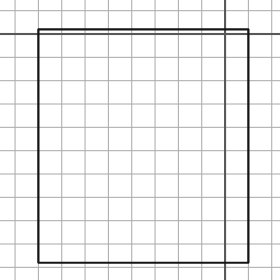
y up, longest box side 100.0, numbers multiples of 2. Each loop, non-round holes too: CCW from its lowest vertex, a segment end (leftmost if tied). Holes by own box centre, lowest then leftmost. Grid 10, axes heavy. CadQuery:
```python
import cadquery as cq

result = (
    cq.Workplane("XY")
    .moveTo(-80.0, -98.0)
    .lineTo(10.0, -98.0)
    .lineTo(10.0, 2.0)
    .lineTo(-80.0, 2.0)
    .close()
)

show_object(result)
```